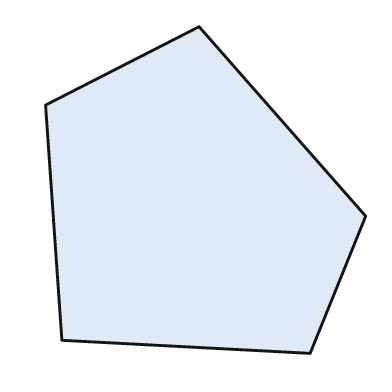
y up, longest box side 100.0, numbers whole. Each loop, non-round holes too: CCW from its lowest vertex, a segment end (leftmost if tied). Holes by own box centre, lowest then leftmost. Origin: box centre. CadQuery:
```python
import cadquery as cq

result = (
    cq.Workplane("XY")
    .moveTo(32.0, -50.0)
    .lineTo(49.0, -8.0)
    .lineTo(-2.0, 50.0)
    .lineTo(-49.0, 26.0)
    .lineTo(-44.0, -46.0)
    .close()
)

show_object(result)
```